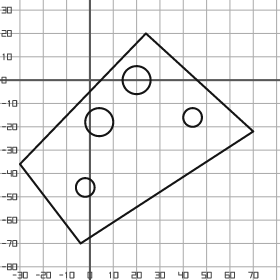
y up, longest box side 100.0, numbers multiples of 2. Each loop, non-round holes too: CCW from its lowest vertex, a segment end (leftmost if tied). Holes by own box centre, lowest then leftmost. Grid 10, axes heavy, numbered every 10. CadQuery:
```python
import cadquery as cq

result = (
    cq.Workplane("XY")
    .moveTo(-4.0, -70.0)
    .lineTo(70.0, -22.0)
    .lineTo(24.0, 20.0)
    .lineTo(-30.0, -36.0)
    .close()
    .moveTo(-2.0, -46.0)
    .circle(4.0)
    .moveTo(4.0, -18.0)
    .circle(6.0)
    .moveTo(44.0, -16.0)
    .circle(4.0)
    .moveTo(20.0, 0.0)
    .circle(6.0)
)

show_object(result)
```